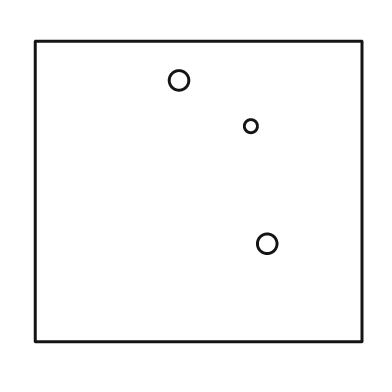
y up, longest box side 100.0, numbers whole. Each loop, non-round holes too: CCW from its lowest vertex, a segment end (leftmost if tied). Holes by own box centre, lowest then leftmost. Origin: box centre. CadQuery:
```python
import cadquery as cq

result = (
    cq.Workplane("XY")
    .moveTo(-50.0, -46.0)
    .lineTo(50.0, -46.0)
    .lineTo(50.0, 46.0)
    .lineTo(-50.0, 46.0)
    .close()
    .moveTo(21.0, -16.0)
    .circle(3.0)
    .moveTo(16.0, 20.0)
    .circle(2.0)
    .moveTo(-6.0, 34.0)
    .circle(3.0)
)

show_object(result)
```